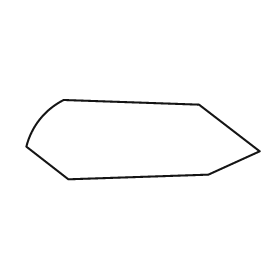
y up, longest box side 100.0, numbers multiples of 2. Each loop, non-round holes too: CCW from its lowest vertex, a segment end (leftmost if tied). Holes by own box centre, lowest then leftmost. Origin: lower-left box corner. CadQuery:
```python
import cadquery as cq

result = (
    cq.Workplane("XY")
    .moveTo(18.0, 0.0)
    .lineTo(78.0, 2.0)
    .lineTo(100.0, 12.0)
    .lineTo(74.0, 32.0)
    .lineTo(16.0, 34.0)
    .threePointArc((6.0, 26.0), (0.0, 14.0))
    .close()
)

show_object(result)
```